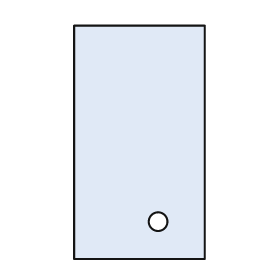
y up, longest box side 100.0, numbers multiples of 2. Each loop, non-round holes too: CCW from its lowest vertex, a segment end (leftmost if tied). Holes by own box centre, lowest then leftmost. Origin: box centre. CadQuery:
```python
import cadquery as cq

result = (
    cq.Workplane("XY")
    .moveTo(-28.0, -50.0)
    .lineTo(28.0, -50.0)
    .lineTo(28.0, 50.0)
    .lineTo(-28.0, 50.0)
    .close()
    .moveTo(8.0, -34.0)
    .circle(4.0)
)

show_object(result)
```